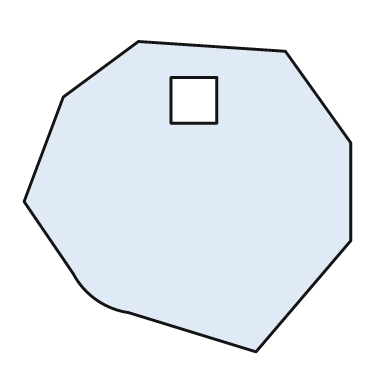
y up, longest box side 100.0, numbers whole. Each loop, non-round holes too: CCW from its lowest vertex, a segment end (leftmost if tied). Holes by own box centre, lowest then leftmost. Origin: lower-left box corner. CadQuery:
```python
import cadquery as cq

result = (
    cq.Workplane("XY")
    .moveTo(71.0, 0.0)
    .lineTo(100.0, 34.0)
    .lineTo(100.0, 64.0)
    .lineTo(80.0, 92.0)
    .lineTo(35.0, 95.0)
    .lineTo(12.0, 78.0)
    .lineTo(0.0, 46.0)
    .lineTo(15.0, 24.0)
    .threePointArc((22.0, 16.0), (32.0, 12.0))
    .close()
    .moveTo(45.0, 70.0)
    .lineTo(59.0, 70.0)
    .lineTo(59.0, 84.0)
    .lineTo(45.0, 84.0)
    .close()
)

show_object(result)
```